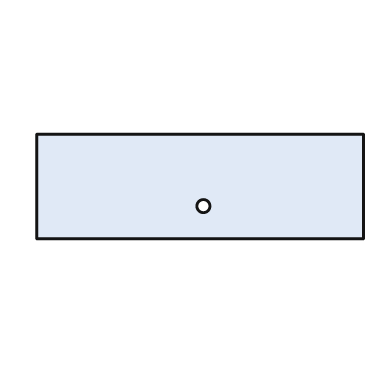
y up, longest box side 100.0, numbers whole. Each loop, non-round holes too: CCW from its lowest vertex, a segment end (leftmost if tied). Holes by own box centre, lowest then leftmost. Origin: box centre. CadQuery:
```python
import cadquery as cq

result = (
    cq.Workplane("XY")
    .moveTo(-50.0, -16.0)
    .lineTo(50.0, -16.0)
    .lineTo(50.0, 16.0)
    .lineTo(-50.0, 16.0)
    .close()
    .moveTo(1.0, -6.0)
    .circle(2.0)
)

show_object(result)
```